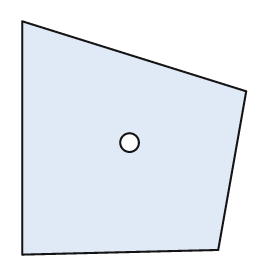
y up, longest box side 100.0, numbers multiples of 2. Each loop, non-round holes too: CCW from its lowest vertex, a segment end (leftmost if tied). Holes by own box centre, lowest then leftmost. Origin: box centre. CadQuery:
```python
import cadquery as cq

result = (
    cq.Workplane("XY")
    .moveTo(-48.0, -50.0)
    .lineTo(36.0, -48.0)
    .lineTo(48.0, 20.0)
    .lineTo(-48.0, 50.0)
    .close()
    .moveTo(-2.0, -2.0)
    .circle(4.0)
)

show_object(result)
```